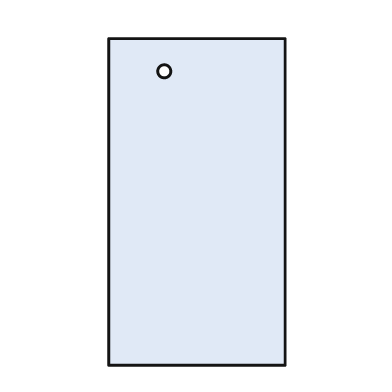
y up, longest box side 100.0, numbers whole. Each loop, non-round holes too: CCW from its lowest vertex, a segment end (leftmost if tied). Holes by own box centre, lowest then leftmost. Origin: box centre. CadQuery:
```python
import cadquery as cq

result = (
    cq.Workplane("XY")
    .moveTo(-27.0, -50.0)
    .lineTo(27.0, -50.0)
    .lineTo(27.0, 50.0)
    .lineTo(-27.0, 50.0)
    .close()
    .moveTo(-10.0, 40.0)
    .circle(2.0)
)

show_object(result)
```